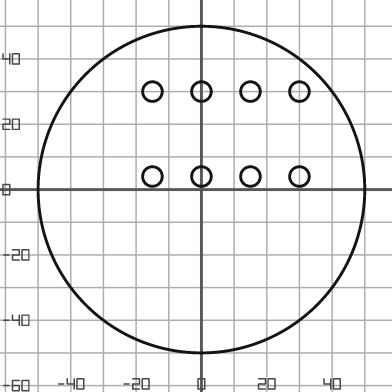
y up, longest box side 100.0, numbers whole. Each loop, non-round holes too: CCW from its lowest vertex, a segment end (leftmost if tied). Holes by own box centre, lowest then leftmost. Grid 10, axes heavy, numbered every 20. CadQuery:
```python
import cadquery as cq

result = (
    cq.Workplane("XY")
    .moveTo(0.0, 0.0)
    .circle(50.0)
    .moveTo(-15.0, 4.0)
    .circle(3.0)
    .moveTo(0.0, 4.0)
    .circle(3.0)
    .moveTo(15.0, 4.0)
    .circle(3.0)
    .moveTo(30.0, 4.0)
    .circle(3.0)
    .moveTo(-15.0, 30.0)
    .circle(3.0)
    .moveTo(0.0, 30.0)
    .circle(3.0)
    .moveTo(15.0, 30.0)
    .circle(3.0)
    .moveTo(30.0, 30.0)
    .circle(3.0)
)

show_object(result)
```